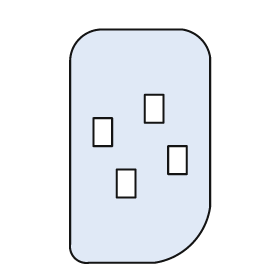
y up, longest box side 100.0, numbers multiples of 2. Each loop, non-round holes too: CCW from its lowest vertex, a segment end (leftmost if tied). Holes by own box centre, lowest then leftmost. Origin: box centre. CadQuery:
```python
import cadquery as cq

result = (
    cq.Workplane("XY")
    .moveTo(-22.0, -50.0)
    .lineTo(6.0, -50.0)
    .threePointArc((22.0, -42.0), (30.0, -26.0))
    .lineTo(30.0, 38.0)
    .threePointArc((26.0, 46.0), (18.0, 50.0))
    .lineTo(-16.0, 50.0)
    .threePointArc((-26.0, 46.0), (-30.0, 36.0))
    .lineTo(-30.0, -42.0)
    .threePointArc((-28.0, -48.0), (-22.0, -50.0))
    .close()
    .moveTo(-10.0, -22.0)
    .lineTo(-2.0, -22.0)
    .lineTo(-2.0, -10.0)
    .lineTo(-10.0, -10.0)
    .close()
    .moveTo(12.0, -12.0)
    .lineTo(20.0, -12.0)
    .lineTo(20.0, 0.0)
    .lineTo(12.0, 0.0)
    .close()
    .moveTo(-20.0, 0.0)
    .lineTo(-12.0, 0.0)
    .lineTo(-12.0, 12.0)
    .lineTo(-20.0, 12.0)
    .close()
    .moveTo(2.0, 10.0)
    .lineTo(10.0, 10.0)
    .lineTo(10.0, 22.0)
    .lineTo(2.0, 22.0)
    .close()
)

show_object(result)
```